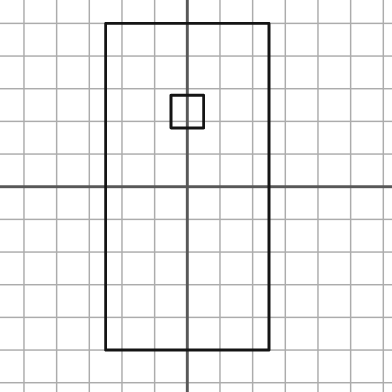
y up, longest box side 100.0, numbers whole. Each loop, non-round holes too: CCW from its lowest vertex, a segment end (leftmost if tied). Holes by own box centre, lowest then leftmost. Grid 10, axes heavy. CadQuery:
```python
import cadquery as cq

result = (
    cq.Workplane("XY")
    .moveTo(-25.0, -50.0)
    .lineTo(25.0, -50.0)
    .lineTo(25.0, 50.0)
    .lineTo(-25.0, 50.0)
    .close()
    .moveTo(-5.0, 18.0)
    .lineTo(5.0, 18.0)
    .lineTo(5.0, 28.0)
    .lineTo(-5.0, 28.0)
    .close()
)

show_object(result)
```